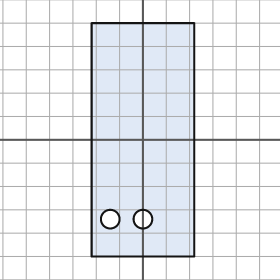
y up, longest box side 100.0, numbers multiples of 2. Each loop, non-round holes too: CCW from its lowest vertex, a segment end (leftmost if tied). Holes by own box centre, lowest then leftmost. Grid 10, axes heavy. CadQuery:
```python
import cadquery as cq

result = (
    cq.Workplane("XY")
    .moveTo(-22.0, -50.0)
    .lineTo(22.0, -50.0)
    .lineTo(22.0, 50.0)
    .lineTo(-22.0, 50.0)
    .close()
    .moveTo(-14.0, -34.0)
    .circle(4.0)
    .moveTo(0.0, -34.0)
    .circle(4.0)
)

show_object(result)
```